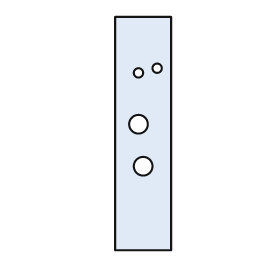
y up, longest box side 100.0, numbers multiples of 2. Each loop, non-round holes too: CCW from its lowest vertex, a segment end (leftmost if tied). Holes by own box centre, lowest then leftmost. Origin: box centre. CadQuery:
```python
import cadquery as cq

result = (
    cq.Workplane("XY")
    .moveTo(-12.0, -50.0)
    .lineTo(12.0, -50.0)
    .lineTo(12.0, 50.0)
    .lineTo(-12.0, 50.0)
    .close()
    .moveTo(0.0, -14.0)
    .circle(4.0)
    .moveTo(-2.0, 4.0)
    .circle(4.0)
    .moveTo(-2.0, 26.0)
    .circle(2.0)
    .moveTo(6.0, 28.0)
    .circle(2.0)
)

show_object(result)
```